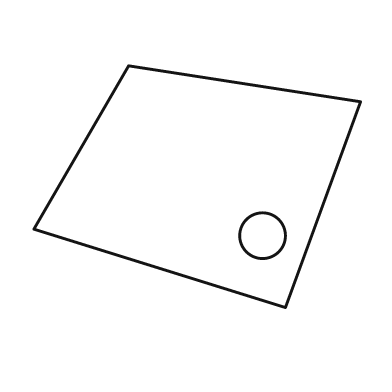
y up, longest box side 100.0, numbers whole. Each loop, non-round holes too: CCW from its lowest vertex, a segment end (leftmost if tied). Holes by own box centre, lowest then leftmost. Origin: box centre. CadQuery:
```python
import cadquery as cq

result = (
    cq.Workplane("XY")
    .moveTo(27.0, -37.0)
    .lineTo(50.0, 26.0)
    .lineTo(-21.0, 37.0)
    .lineTo(-50.0, -13.0)
    .close()
    .moveTo(20.0, -15.0)
    .circle(7.0)
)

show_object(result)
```